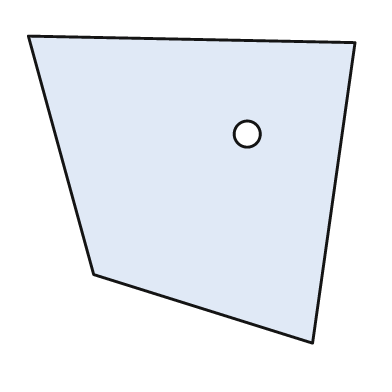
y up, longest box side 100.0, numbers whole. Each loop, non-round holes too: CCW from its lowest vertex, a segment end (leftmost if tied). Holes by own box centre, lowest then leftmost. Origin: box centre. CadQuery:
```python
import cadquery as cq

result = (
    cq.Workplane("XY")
    .moveTo(37.0, -47.0)
    .lineTo(50.0, 45.0)
    .lineTo(-50.0, 47.0)
    .lineTo(-30.0, -26.0)
    .close()
    .moveTo(17.0, 17.0)
    .circle(4.0)
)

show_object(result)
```